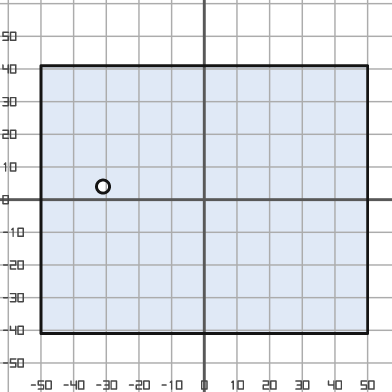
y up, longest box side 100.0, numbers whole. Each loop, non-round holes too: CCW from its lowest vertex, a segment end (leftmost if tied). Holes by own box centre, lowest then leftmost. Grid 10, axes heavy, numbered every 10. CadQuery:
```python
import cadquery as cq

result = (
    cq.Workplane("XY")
    .moveTo(-50.0, -41.0)
    .lineTo(50.0, -41.0)
    .lineTo(50.0, 41.0)
    .lineTo(-50.0, 41.0)
    .close()
    .moveTo(-31.0, 4.0)
    .circle(2.0)
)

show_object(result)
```